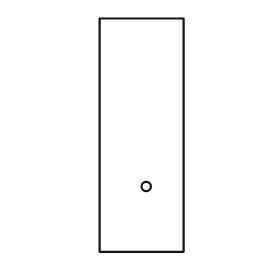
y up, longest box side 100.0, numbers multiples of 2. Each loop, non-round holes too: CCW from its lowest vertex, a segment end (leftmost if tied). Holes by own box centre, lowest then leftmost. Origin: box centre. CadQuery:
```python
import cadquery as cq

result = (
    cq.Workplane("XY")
    .moveTo(-18.0, -50.0)
    .lineTo(18.0, -50.0)
    .lineTo(18.0, 50.0)
    .lineTo(-18.0, 50.0)
    .close()
    .moveTo(2.0, -22.0)
    .circle(2.0)
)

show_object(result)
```